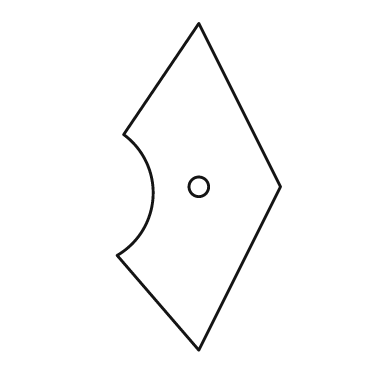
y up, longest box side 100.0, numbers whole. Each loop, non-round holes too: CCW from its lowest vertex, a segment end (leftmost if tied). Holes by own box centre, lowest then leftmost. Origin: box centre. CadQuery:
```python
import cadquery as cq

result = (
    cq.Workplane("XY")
    .moveTo(0.0, -50.0)
    .lineTo(25.0, 0.0)
    .lineTo(0.0, 50.0)
    .lineTo(-23.0, 16.0)
    .threePointArc((-14.0, -3.0), (-25.0, -21.0))
    .close()
    .moveTo(0.0, 0.0)
    .circle(3.0)
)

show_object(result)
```